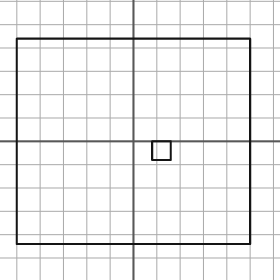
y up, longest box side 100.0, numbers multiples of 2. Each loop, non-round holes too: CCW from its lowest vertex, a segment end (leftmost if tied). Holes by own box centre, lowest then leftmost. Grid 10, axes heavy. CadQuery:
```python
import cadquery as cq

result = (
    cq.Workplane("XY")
    .moveTo(-50.0, -44.0)
    .lineTo(50.0, -44.0)
    .lineTo(50.0, 44.0)
    .lineTo(-50.0, 44.0)
    .close()
    .moveTo(8.0, -8.0)
    .lineTo(16.0, -8.0)
    .lineTo(16.0, 0.0)
    .lineTo(8.0, 0.0)
    .close()
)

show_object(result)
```